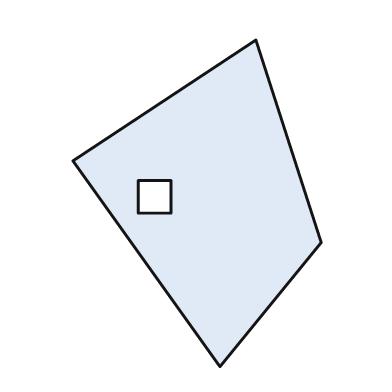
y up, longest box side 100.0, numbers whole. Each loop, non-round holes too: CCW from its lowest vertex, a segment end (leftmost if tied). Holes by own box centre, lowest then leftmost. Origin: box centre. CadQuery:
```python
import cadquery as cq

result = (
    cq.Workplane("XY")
    .moveTo(7.0, -50.0)
    .lineTo(38.0, -12.0)
    .lineTo(18.0, 50.0)
    .lineTo(-38.0, 13.0)
    .close()
    .moveTo(-18.0, -3.0)
    .lineTo(-8.0, -3.0)
    .lineTo(-8.0, 7.0)
    .lineTo(-18.0, 7.0)
    .close()
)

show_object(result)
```